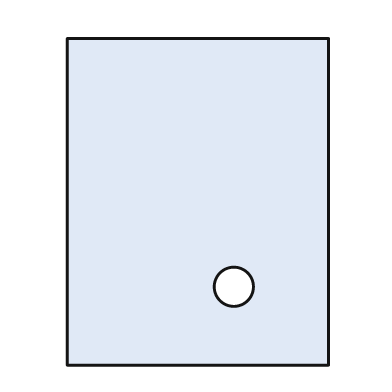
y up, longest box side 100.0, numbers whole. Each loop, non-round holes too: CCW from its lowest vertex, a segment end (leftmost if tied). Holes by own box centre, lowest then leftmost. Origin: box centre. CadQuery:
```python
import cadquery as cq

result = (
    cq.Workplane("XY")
    .moveTo(-40.0, -50.0)
    .lineTo(40.0, -50.0)
    .lineTo(40.0, 50.0)
    .lineTo(-40.0, 50.0)
    .close()
    .moveTo(11.0, -26.0)
    .circle(6.0)
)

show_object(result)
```